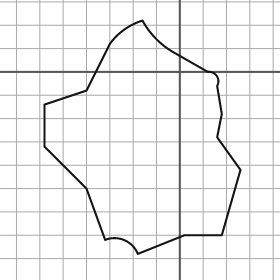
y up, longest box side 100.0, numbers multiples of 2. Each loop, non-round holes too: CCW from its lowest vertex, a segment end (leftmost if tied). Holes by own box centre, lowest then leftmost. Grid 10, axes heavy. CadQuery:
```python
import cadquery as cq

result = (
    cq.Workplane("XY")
    .moveTo(-18.0, -78.0)
    .lineTo(2.0, -70.0)
    .lineTo(18.0, -70.0)
    .lineTo(26.0, -42.0)
    .lineTo(16.0, -28.0)
    .lineTo(18.0, -18.0)
    .lineTo(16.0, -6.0)
    .threePointArc((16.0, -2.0), (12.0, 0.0))
    .lineTo(-2.0, 8.0)
    .threePointArc((-10.0, 14.0), (-16.0, 22.0))
    .threePointArc((-24.0, 18.0), (-30.0, 12.0))
    .lineTo(-40.0, -8.0)
    .lineTo(-58.0, -14.0)
    .lineTo(-58.0, -32.0)
    .lineTo(-40.0, -50.0)
    .lineTo(-32.0, -72.0)
    .threePointArc((-24.0, -72.0), (-18.0, -78.0))
    .close()
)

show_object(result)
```